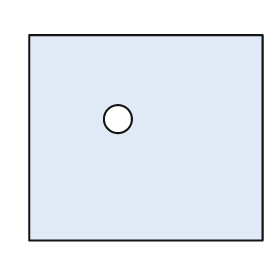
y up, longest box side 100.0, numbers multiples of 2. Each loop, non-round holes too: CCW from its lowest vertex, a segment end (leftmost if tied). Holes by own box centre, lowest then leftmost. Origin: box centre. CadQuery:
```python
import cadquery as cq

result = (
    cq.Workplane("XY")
    .moveTo(-50.0, -44.0)
    .lineTo(50.0, -44.0)
    .lineTo(50.0, 44.0)
    .lineTo(-50.0, 44.0)
    .close()
    .moveTo(-12.0, 8.0)
    .circle(6.0)
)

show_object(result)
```